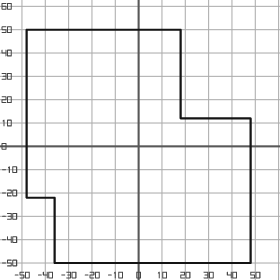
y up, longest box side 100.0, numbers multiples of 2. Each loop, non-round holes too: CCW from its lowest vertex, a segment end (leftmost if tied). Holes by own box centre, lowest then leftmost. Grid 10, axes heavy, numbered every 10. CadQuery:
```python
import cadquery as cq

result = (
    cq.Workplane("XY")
    .moveTo(-36.0, -50.0)
    .lineTo(48.0, -50.0)
    .lineTo(48.0, 12.0)
    .lineTo(18.0, 12.0)
    .lineTo(18.0, 50.0)
    .lineTo(-48.0, 50.0)
    .lineTo(-48.0, -22.0)
    .lineTo(-36.0, -22.0)
    .close()
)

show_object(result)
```